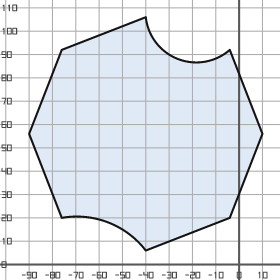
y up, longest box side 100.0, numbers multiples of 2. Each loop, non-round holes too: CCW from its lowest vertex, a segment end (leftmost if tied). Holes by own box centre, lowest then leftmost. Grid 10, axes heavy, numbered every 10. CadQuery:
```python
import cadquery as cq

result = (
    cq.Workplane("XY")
    .moveTo(-40.0, 6.0)
    .lineTo(-4.0, 20.0)
    .lineTo(10.0, 56.0)
    .lineTo(-4.0, 92.0)
    .threePointArc((-26.0, 88.0), (-40.0, 106.0))
    .lineTo(-76.0, 92.0)
    .lineTo(-90.0, 56.0)
    .lineTo(-76.0, 20.0)
    .threePointArc((-56.0, 18.0), (-40.0, 6.0))
    .close()
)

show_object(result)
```